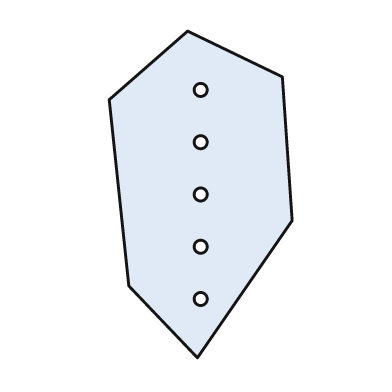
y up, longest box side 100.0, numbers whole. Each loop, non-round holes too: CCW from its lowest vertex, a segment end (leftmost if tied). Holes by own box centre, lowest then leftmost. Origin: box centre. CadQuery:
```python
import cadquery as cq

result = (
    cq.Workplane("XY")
    .moveTo(-1.0, -50.0)
    .lineTo(28.0, -8.0)
    .lineTo(25.0, 36.0)
    .lineTo(-4.0, 50.0)
    .lineTo(-28.0, 29.0)
    .lineTo(-22.0, -28.0)
    .close()
    .moveTo(0.0, -32.0)
    .circle(2.0)
    .moveTo(0.0, -16.0)
    .circle(2.0)
    .moveTo(0.0, 0.0)
    .circle(2.0)
    .moveTo(0.0, 16.0)
    .circle(2.0)
    .moveTo(0.0, 32.0)
    .circle(2.0)
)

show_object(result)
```